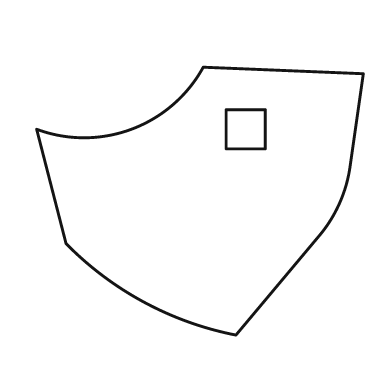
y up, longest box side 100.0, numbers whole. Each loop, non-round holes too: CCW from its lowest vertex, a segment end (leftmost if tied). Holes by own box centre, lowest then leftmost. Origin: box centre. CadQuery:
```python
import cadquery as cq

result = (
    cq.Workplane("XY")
    .moveTo(11.0, -41.0)
    .lineTo(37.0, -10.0)
    .threePointArc((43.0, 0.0), (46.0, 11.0))
    .lineTo(50.0, 39.0)
    .lineTo(1.0, 41.0)
    .threePointArc((-21.0, 22.0), (-50.0, 22.0))
    .lineTo(-41.0, -13.0)
    .threePointArc((-17.0, -31.0), (11.0, -41.0))
    .close()
    .moveTo(8.0, 16.0)
    .lineTo(20.0, 16.0)
    .lineTo(20.0, 28.0)
    .lineTo(8.0, 28.0)
    .close()
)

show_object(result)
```